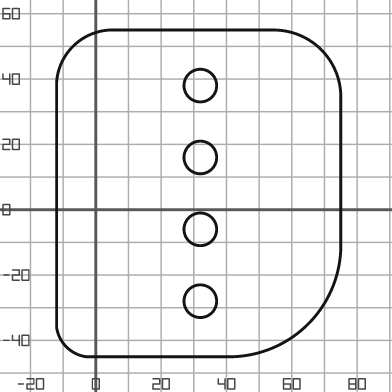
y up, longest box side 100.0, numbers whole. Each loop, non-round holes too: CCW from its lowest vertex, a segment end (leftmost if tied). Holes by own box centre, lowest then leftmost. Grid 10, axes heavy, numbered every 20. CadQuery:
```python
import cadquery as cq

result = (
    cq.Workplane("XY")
    .moveTo(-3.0, -45.0)
    .lineTo(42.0, -45.0)
    .threePointArc((65.0, -35.0), (75.0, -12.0))
    .lineTo(75.0, 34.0)
    .threePointArc((69.0, 49.0), (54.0, 55.0))
    .lineTo(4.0, 55.0)
    .threePointArc((-7.0, 50.0), (-12.0, 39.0))
    .lineTo(-12.0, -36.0)
    .threePointArc((-9.0, -42.0), (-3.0, -45.0))
    .close()
    .moveTo(32.0, -28.0)
    .circle(5.0)
    .moveTo(32.0, -6.0)
    .circle(5.0)
    .moveTo(32.0, 16.0)
    .circle(5.0)
    .moveTo(32.0, 38.0)
    .circle(5.0)
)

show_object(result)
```